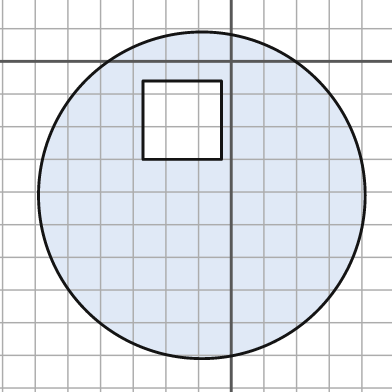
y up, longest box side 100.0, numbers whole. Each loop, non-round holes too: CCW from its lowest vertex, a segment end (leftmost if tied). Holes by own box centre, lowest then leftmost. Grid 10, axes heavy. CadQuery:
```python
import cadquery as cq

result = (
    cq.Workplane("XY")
    .moveTo(-9.0, -41.0)
    .circle(50.0)
    .moveTo(-27.0, -30.0)
    .lineTo(-3.0, -30.0)
    .lineTo(-3.0, -6.0)
    .lineTo(-27.0, -6.0)
    .close()
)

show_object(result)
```